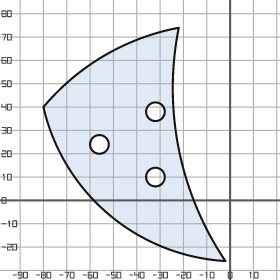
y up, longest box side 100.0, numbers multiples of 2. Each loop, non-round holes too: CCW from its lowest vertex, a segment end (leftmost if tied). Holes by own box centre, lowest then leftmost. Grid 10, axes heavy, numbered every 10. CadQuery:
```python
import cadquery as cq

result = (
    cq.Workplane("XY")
    .moveTo(-2.0, -26.0)
    .threePointArc((-22.0, 22.0), (-22.0, 74.0))
    .threePointArc((-54.0, 62.0), (-80.0, 40.0))
    .threePointArc((-52.0, -6.0), (-2.0, -26.0))
    .close()
    .moveTo(-32.0, 10.0)
    .circle(4.0)
    .moveTo(-56.0, 24.0)
    .circle(4.0)
    .moveTo(-32.0, 38.0)
    .circle(4.0)
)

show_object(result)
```